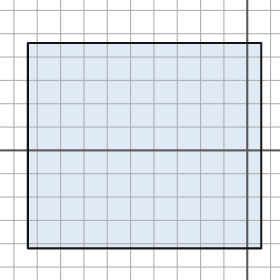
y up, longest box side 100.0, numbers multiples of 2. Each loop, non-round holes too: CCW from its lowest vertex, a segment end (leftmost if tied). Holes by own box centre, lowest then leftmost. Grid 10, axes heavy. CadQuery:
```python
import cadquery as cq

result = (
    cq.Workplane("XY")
    .moveTo(-94.0, -42.0)
    .lineTo(6.0, -42.0)
    .lineTo(6.0, 46.0)
    .lineTo(-94.0, 46.0)
    .close()
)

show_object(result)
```